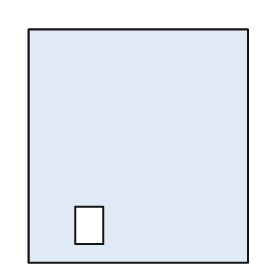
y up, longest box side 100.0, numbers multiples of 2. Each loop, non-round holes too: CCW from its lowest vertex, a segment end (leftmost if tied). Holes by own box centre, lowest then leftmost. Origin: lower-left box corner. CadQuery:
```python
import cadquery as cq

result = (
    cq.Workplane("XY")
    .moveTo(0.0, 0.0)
    .lineTo(94.0, 0.0)
    .lineTo(94.0, 100.0)
    .lineTo(0.0, 100.0)
    .close()
    .moveTo(20.0, 8.0)
    .lineTo(32.0, 8.0)
    .lineTo(32.0, 24.0)
    .lineTo(20.0, 24.0)
    .close()
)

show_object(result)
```